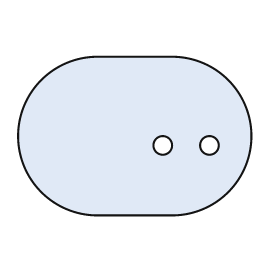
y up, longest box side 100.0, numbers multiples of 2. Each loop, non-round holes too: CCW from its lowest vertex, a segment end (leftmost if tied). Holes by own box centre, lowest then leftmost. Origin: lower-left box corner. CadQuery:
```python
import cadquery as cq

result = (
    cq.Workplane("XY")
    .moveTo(34.0, 0.0)
    .lineTo(66.0, 0.0)
    .threePointArc((100.0, 34.0), (66.0, 68.0))
    .lineTo(34.0, 68.0)
    .threePointArc((0.0, 34.0), (34.0, 0.0))
    .close()
    .moveTo(62.0, 30.0)
    .circle(4.0)
    .moveTo(82.0, 30.0)
    .circle(4.0)
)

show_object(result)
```